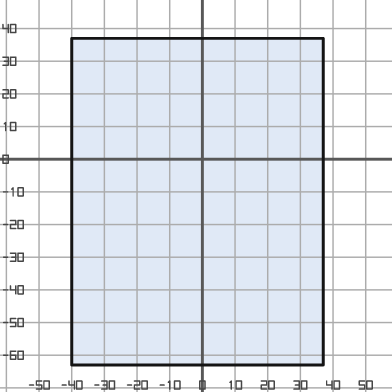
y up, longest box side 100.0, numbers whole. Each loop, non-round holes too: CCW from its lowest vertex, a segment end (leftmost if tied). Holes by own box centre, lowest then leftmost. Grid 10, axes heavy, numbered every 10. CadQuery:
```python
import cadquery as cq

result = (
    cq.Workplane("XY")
    .moveTo(-40.0, -63.0)
    .lineTo(37.0, -63.0)
    .lineTo(37.0, 37.0)
    .lineTo(-40.0, 37.0)
    .close()
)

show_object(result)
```